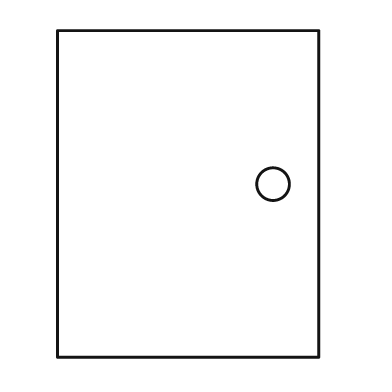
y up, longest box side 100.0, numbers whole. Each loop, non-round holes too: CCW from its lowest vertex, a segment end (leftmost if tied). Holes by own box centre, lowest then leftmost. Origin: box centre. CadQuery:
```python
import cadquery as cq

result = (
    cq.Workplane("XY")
    .moveTo(-40.0, -50.0)
    .lineTo(40.0, -50.0)
    .lineTo(40.0, 50.0)
    .lineTo(-40.0, 50.0)
    .close()
    .moveTo(26.0, 3.0)
    .circle(5.0)
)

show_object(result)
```